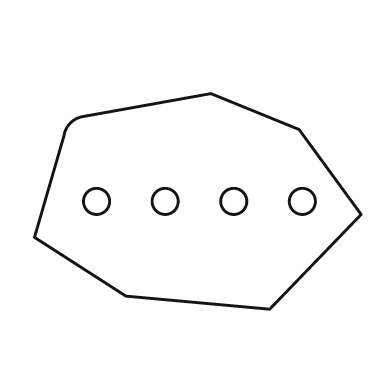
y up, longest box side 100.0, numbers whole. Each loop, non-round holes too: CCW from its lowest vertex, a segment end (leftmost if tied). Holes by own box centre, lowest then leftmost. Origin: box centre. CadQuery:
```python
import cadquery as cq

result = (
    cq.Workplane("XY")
    .moveTo(22.0, -33.0)
    .lineTo(50.0, -4.0)
    .lineTo(31.0, 22.0)
    .lineTo(4.0, 33.0)
    .lineTo(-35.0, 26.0)
    .threePointArc((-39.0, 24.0), (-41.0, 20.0))
    .lineTo(-50.0, -11.0)
    .lineTo(-22.0, -29.0)
    .close()
    .moveTo(-31.0, 0.0)
    .circle(4.0)
    .moveTo(-10.0, 0.0)
    .circle(4.0)
    .moveTo(11.0, 0.0)
    .circle(4.0)
    .moveTo(32.0, 0.0)
    .circle(4.0)
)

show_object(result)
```